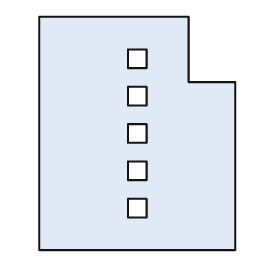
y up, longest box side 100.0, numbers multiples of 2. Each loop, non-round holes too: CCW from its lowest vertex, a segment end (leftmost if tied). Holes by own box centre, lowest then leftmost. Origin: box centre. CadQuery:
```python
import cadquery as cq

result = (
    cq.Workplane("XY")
    .moveTo(-42.0, -50.0)
    .lineTo(42.0, -50.0)
    .lineTo(42.0, 22.0)
    .lineTo(22.0, 22.0)
    .lineTo(22.0, 50.0)
    .lineTo(-42.0, 50.0)
    .close()
    .moveTo(-4.0, -36.0)
    .lineTo(4.0, -36.0)
    .lineTo(4.0, -28.0)
    .lineTo(-4.0, -28.0)
    .close()
    .moveTo(-4.0, -20.0)
    .lineTo(4.0, -20.0)
    .lineTo(4.0, -12.0)
    .lineTo(-4.0, -12.0)
    .close()
    .moveTo(-4.0, -4.0)
    .lineTo(4.0, -4.0)
    .lineTo(4.0, 4.0)
    .lineTo(-4.0, 4.0)
    .close()
    .moveTo(-4.0, 12.0)
    .lineTo(4.0, 12.0)
    .lineTo(4.0, 20.0)
    .lineTo(-4.0, 20.0)
    .close()
    .moveTo(-4.0, 28.0)
    .lineTo(4.0, 28.0)
    .lineTo(4.0, 36.0)
    .lineTo(-4.0, 36.0)
    .close()
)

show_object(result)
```